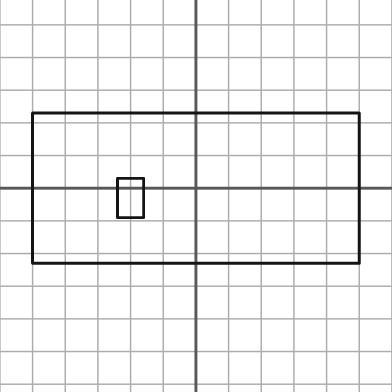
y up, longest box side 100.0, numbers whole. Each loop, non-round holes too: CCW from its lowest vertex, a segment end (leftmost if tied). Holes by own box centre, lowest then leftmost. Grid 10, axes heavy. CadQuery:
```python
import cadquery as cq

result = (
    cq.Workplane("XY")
    .moveTo(-50.0, -23.0)
    .lineTo(50.0, -23.0)
    .lineTo(50.0, 23.0)
    .lineTo(-50.0, 23.0)
    .close()
    .moveTo(-24.0, -9.0)
    .lineTo(-16.0, -9.0)
    .lineTo(-16.0, 3.0)
    .lineTo(-24.0, 3.0)
    .close()
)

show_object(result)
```